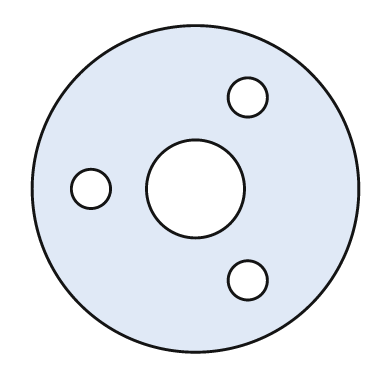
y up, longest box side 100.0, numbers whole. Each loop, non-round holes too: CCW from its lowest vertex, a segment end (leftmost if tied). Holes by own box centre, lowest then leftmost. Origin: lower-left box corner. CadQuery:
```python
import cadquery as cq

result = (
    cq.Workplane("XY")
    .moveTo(50.0, 50.0)
    .circle(50.0)
    .moveTo(66.0, 22.0)
    .circle(6.0)
    .moveTo(18.0, 50.0)
    .circle(6.0)
    .moveTo(50.0, 50.0)
    .circle(15.0)
    .moveTo(66.0, 78.0)
    .circle(6.0)
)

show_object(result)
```